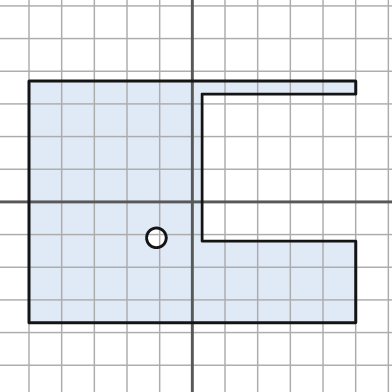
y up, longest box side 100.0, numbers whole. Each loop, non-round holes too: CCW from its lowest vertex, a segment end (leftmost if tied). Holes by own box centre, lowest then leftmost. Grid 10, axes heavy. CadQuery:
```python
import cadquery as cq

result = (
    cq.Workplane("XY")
    .moveTo(-50.0, -37.0)
    .lineTo(50.0, -37.0)
    .lineTo(50.0, -12.0)
    .lineTo(3.0, -12.0)
    .lineTo(3.0, 33.0)
    .lineTo(50.0, 33.0)
    .lineTo(50.0, 37.0)
    .lineTo(-50.0, 37.0)
    .close()
    .moveTo(-11.0, -11.0)
    .circle(3.0)
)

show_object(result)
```